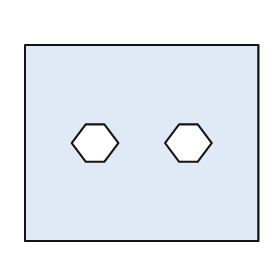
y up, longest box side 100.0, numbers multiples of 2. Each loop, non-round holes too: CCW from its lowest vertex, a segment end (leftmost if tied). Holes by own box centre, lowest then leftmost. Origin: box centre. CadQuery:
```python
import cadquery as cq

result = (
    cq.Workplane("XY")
    .moveTo(-50.0, -42.0)
    .lineTo(50.0, -42.0)
    .lineTo(50.0, 42.0)
    .lineTo(-50.0, 42.0)
    .close()
    .moveTo(-24.0, -8.0)
    .lineTo(-16.0, -8.0)
    .lineTo(-10.0, 0.0)
    .lineTo(-16.0, 8.0)
    .lineTo(-24.0, 8.0)
    .lineTo(-30.0, 0.0)
    .close()
    .moveTo(16.0, -8.0)
    .lineTo(24.0, -8.0)
    .lineTo(30.0, 0.0)
    .lineTo(24.0, 8.0)
    .lineTo(16.0, 8.0)
    .lineTo(10.0, 0.0)
    .close()
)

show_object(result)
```